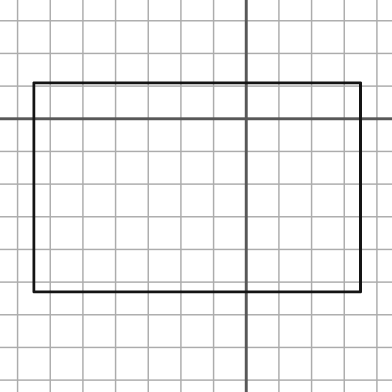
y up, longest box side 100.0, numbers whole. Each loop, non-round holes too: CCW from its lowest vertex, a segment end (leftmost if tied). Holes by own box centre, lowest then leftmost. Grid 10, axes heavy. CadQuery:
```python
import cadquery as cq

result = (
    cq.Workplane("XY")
    .moveTo(-65.0, -53.0)
    .lineTo(35.0, -53.0)
    .lineTo(35.0, 11.0)
    .lineTo(-65.0, 11.0)
    .close()
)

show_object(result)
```